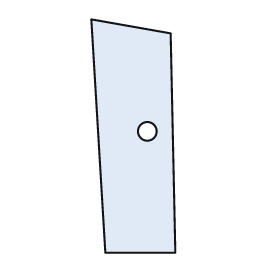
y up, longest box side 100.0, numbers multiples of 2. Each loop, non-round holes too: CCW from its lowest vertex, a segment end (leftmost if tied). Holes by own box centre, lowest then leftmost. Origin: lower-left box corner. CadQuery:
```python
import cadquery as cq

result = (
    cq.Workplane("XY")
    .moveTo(6.0, 0.0)
    .lineTo(36.0, 0.0)
    .lineTo(34.0, 94.0)
    .lineTo(0.0, 100.0)
    .close()
    .moveTo(24.0, 52.0)
    .circle(4.0)
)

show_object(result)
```